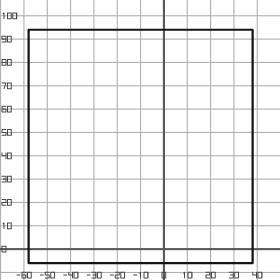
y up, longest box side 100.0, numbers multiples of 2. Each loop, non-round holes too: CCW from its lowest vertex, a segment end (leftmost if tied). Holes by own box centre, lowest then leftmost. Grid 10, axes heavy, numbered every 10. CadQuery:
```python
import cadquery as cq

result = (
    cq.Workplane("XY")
    .moveTo(-58.0, -6.0)
    .lineTo(38.0, -6.0)
    .lineTo(38.0, 94.0)
    .lineTo(-58.0, 94.0)
    .close()
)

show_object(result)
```